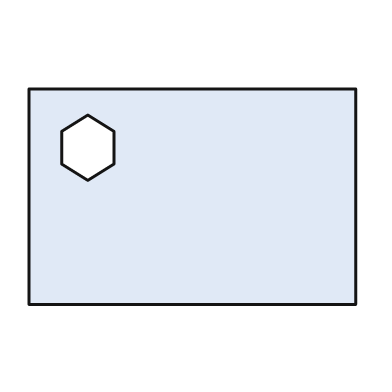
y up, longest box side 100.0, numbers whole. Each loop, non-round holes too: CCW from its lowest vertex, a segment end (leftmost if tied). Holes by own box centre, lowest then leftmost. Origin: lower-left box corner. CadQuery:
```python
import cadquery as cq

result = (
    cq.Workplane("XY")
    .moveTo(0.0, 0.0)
    .lineTo(100.0, 0.0)
    .lineTo(100.0, 66.0)
    .lineTo(0.0, 66.0)
    .close()
    .moveTo(18.0, 38.0)
    .lineTo(26.0, 43.0)
    .lineTo(26.0, 53.0)
    .lineTo(18.0, 58.0)
    .lineTo(10.0, 53.0)
    .lineTo(10.0, 43.0)
    .close()
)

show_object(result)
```